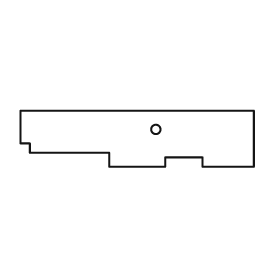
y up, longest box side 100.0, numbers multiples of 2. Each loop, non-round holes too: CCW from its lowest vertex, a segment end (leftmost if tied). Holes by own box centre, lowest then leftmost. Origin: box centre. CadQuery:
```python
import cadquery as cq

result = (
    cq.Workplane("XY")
    .moveTo(-12.0, -12.0)
    .lineTo(12.0, -12.0)
    .lineTo(12.0, -8.0)
    .lineTo(28.0, -8.0)
    .lineTo(28.0, -12.0)
    .lineTo(50.0, -12.0)
    .lineTo(50.0, 12.0)
    .lineTo(-50.0, 12.0)
    .lineTo(-50.0, -2.0)
    .lineTo(-46.0, -2.0)
    .lineTo(-46.0, -6.0)
    .lineTo(-12.0, -6.0)
    .close()
    .moveTo(8.0, 4.0)
    .circle(2.0)
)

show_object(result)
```